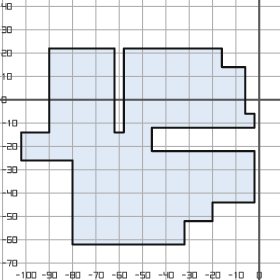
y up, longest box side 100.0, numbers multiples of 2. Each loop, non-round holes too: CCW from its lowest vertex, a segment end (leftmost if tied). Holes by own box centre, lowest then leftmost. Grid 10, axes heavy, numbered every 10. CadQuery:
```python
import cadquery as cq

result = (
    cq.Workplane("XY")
    .moveTo(-80.0, -62.0)
    .lineTo(-32.0, -62.0)
    .lineTo(-32.0, -52.0)
    .lineTo(-20.0, -52.0)
    .lineTo(-20.0, -44.0)
    .lineTo(-2.0, -44.0)
    .lineTo(-2.0, -22.0)
    .lineTo(-46.0, -22.0)
    .lineTo(-46.0, -12.0)
    .lineTo(-2.0, -12.0)
    .lineTo(-2.0, -6.0)
    .lineTo(-6.0, -6.0)
    .lineTo(-6.0, 14.0)
    .lineTo(-16.0, 14.0)
    .lineTo(-16.0, 22.0)
    .lineTo(-58.0, 22.0)
    .lineTo(-58.0, -14.0)
    .lineTo(-62.0, -14.0)
    .lineTo(-62.0, 22.0)
    .lineTo(-90.0, 22.0)
    .lineTo(-90.0, -14.0)
    .lineTo(-102.0, -14.0)
    .lineTo(-102.0, -26.0)
    .lineTo(-80.0, -26.0)
    .close()
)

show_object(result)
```